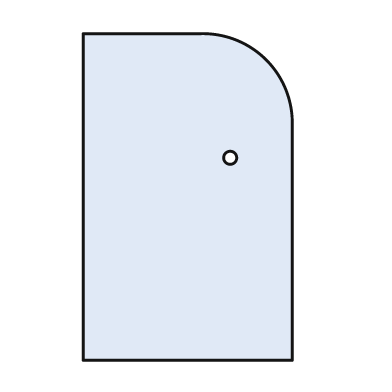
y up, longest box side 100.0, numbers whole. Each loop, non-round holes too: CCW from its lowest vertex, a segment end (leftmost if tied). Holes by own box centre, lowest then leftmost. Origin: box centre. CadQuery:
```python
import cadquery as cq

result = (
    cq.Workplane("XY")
    .moveTo(-32.0, -50.0)
    .lineTo(32.0, -50.0)
    .lineTo(32.0, 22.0)
    .threePointArc((24.0, 42.0), (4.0, 50.0))
    .lineTo(-32.0, 50.0)
    .close()
    .moveTo(13.0, 12.0)
    .circle(2.0)
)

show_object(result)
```